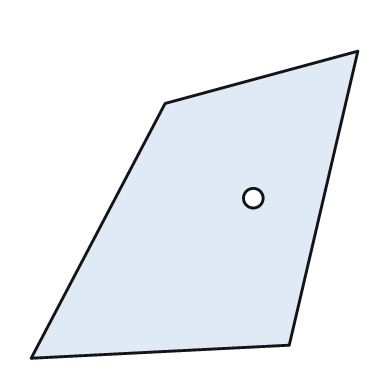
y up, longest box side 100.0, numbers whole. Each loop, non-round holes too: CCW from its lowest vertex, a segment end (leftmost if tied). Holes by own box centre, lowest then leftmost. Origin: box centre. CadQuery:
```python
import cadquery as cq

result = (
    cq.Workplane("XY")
    .moveTo(-50.0, -47.0)
    .lineTo(29.0, -43.0)
    .lineTo(50.0, 47.0)
    .lineTo(-9.0, 31.0)
    .close()
    .moveTo(18.0, 2.0)
    .circle(3.0)
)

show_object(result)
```